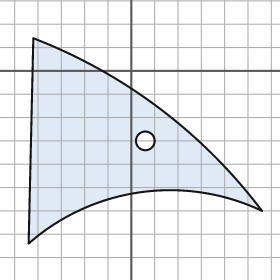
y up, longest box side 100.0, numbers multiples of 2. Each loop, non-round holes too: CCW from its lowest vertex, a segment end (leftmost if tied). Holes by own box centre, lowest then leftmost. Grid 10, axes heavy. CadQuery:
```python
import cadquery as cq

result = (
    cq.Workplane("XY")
    .moveTo(-44.0, -74.0)
    .threePointArc((4.0, -52.0), (56.0, -60.0))
    .threePointArc((12.0, -16.0), (-42.0, 14.0))
    .close()
    .moveTo(6.0, -30.0)
    .circle(4.0)
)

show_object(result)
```